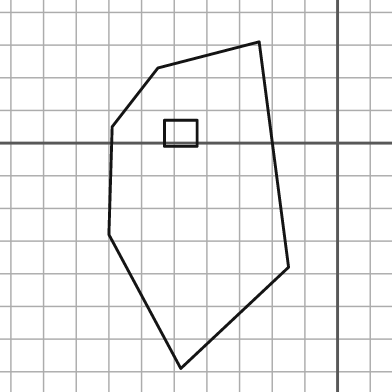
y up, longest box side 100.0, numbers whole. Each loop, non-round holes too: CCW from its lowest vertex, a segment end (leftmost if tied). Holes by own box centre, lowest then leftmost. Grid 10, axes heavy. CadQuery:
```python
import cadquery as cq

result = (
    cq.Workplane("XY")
    .moveTo(-48.0, -69.0)
    .lineTo(-15.0, -38.0)
    .lineTo(-24.0, 31.0)
    .lineTo(-55.0, 23.0)
    .lineTo(-69.0, 5.0)
    .lineTo(-70.0, -28.0)
    .close()
    .moveTo(-53.0, -1.0)
    .lineTo(-43.0, -1.0)
    .lineTo(-43.0, 7.0)
    .lineTo(-53.0, 7.0)
    .close()
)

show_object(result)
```